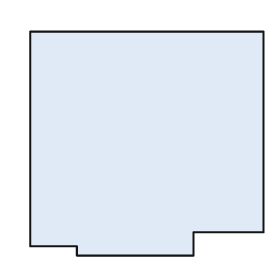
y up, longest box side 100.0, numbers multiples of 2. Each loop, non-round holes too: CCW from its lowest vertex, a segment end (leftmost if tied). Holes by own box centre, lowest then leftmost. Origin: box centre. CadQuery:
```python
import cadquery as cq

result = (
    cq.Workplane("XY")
    .moveTo(-30.0, -48.0)
    .lineTo(20.0, -48.0)
    .lineTo(20.0, -38.0)
    .lineTo(50.0, -38.0)
    .lineTo(50.0, 48.0)
    .lineTo(-50.0, 48.0)
    .lineTo(-50.0, -44.0)
    .lineTo(-30.0, -44.0)
    .close()
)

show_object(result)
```